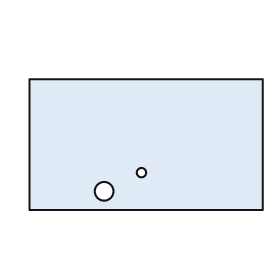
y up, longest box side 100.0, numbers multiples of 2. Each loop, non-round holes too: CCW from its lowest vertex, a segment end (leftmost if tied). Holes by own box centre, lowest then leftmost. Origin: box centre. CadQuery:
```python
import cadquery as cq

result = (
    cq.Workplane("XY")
    .moveTo(-50.0, -28.0)
    .lineTo(50.0, -28.0)
    .lineTo(50.0, 28.0)
    .lineTo(-50.0, 28.0)
    .close()
    .moveTo(-18.0, -20.0)
    .circle(4.0)
    .moveTo(-2.0, -12.0)
    .circle(2.0)
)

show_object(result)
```